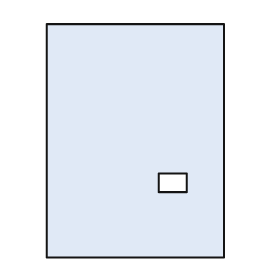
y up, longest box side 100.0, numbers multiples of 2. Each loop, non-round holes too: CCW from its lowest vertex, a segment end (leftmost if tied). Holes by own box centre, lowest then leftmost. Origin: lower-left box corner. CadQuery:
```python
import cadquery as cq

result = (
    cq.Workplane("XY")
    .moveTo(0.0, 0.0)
    .lineTo(76.0, 0.0)
    .lineTo(76.0, 100.0)
    .lineTo(0.0, 100.0)
    .close()
    .moveTo(48.0, 28.0)
    .lineTo(60.0, 28.0)
    .lineTo(60.0, 36.0)
    .lineTo(48.0, 36.0)
    .close()
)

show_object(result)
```